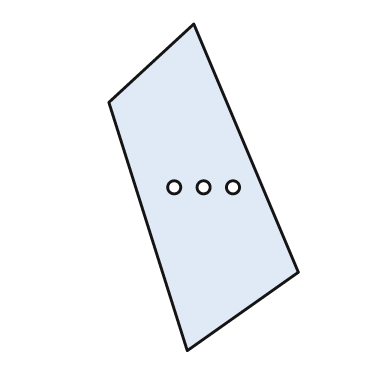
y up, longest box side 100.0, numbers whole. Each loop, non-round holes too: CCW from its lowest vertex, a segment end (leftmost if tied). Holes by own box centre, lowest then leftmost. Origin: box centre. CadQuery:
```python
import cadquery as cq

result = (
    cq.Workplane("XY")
    .moveTo(-5.0, -50.0)
    .lineTo(29.0, -26.0)
    .lineTo(-3.0, 50.0)
    .lineTo(-29.0, 26.0)
    .close()
    .moveTo(-9.0, 0.0)
    .circle(2.0)
    .moveTo(0.0, 0.0)
    .circle(2.0)
    .moveTo(9.0, 0.0)
    .circle(2.0)
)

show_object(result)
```